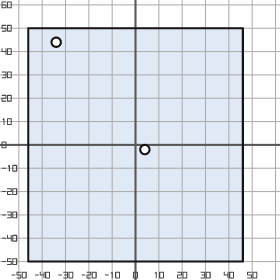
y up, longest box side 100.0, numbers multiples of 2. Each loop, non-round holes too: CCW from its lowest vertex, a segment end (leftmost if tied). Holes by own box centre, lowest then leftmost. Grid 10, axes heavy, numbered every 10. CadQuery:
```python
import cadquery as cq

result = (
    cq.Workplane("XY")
    .moveTo(-46.0, -50.0)
    .lineTo(46.0, -50.0)
    .lineTo(46.0, 50.0)
    .lineTo(-46.0, 50.0)
    .close()
    .moveTo(4.0, -2.0)
    .circle(2.0)
    .moveTo(-34.0, 44.0)
    .circle(2.0)
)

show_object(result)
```